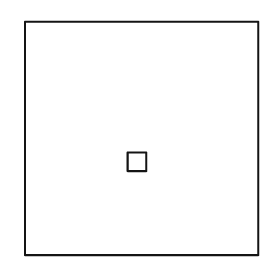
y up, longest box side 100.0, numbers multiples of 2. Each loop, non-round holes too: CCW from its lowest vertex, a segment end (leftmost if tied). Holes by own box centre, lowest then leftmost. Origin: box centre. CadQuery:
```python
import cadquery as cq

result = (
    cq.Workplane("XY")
    .moveTo(-50.0, -50.0)
    .lineTo(50.0, -50.0)
    .lineTo(50.0, 50.0)
    .lineTo(-50.0, 50.0)
    .close()
    .moveTo(-6.0, -14.0)
    .lineTo(2.0, -14.0)
    .lineTo(2.0, -6.0)
    .lineTo(-6.0, -6.0)
    .close()
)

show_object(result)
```